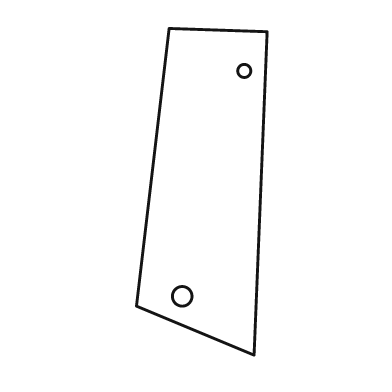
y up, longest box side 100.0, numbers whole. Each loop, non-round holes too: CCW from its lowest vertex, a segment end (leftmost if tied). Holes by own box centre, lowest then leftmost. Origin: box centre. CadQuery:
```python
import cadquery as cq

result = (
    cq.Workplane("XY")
    .moveTo(16.0, -50.0)
    .lineTo(20.0, 49.0)
    .lineTo(-10.0, 50.0)
    .lineTo(-20.0, -35.0)
    .close()
    .moveTo(-6.0, -32.0)
    .circle(3.0)
    .moveTo(13.0, 37.0)
    .circle(2.0)
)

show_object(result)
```